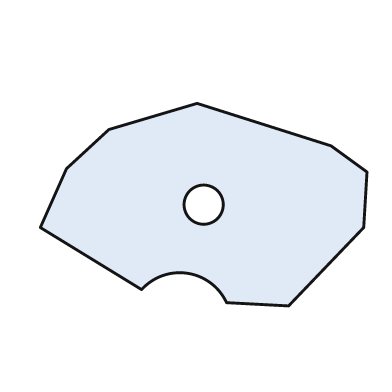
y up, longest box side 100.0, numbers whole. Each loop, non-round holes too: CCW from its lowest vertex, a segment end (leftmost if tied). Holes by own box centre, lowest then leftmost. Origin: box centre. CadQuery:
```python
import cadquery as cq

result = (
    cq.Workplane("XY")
    .moveTo(26.0, -31.0)
    .lineTo(49.0, -7.0)
    .lineTo(50.0, 10.0)
    .lineTo(39.0, 18.0)
    .lineTo(-2.0, 31.0)
    .lineTo(-29.0, 23.0)
    .lineTo(-42.0, 11.0)
    .lineTo(-50.0, -7.0)
    .lineTo(-19.0, -26.0)
    .threePointArc((-5.0, -21.0), (7.0, -30.0))
    .close()
    .moveTo(0.0, 0.0)
    .circle(6.0)
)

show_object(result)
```